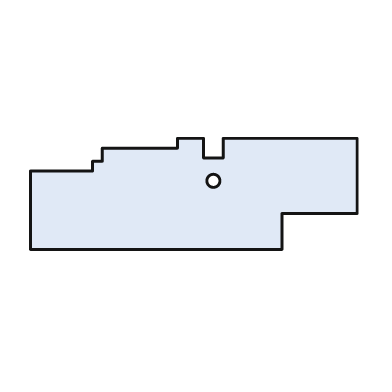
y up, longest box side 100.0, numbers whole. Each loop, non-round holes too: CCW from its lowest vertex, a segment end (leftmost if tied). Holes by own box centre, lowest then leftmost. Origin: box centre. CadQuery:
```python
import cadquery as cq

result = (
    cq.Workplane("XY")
    .moveTo(-50.0, -17.0)
    .lineTo(27.0, -17.0)
    .lineTo(27.0, -6.0)
    .lineTo(50.0, -6.0)
    .lineTo(50.0, 17.0)
    .lineTo(9.0, 17.0)
    .lineTo(9.0, 11.0)
    .lineTo(3.0, 11.0)
    .lineTo(3.0, 17.0)
    .lineTo(-5.0, 17.0)
    .lineTo(-5.0, 14.0)
    .lineTo(-28.0, 14.0)
    .lineTo(-28.0, 10.0)
    .lineTo(-31.0, 10.0)
    .lineTo(-31.0, 7.0)
    .lineTo(-50.0, 7.0)
    .close()
    .moveTo(6.0, 4.0)
    .circle(2.0)
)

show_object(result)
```